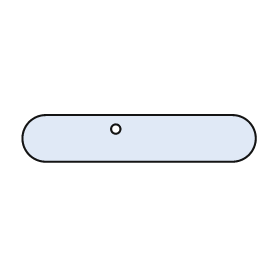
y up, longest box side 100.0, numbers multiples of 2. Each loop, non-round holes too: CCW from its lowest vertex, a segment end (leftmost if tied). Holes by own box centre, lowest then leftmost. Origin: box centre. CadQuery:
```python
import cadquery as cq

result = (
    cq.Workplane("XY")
    .moveTo(-40.0, -10.0)
    .lineTo(40.0, -10.0)
    .threePointArc((50.0, 0.0), (40.0, 10.0))
    .lineTo(-40.0, 10.0)
    .threePointArc((-50.0, 0.0), (-40.0, -10.0))
    .close()
    .moveTo(-10.0, 4.0)
    .circle(2.0)
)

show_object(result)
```